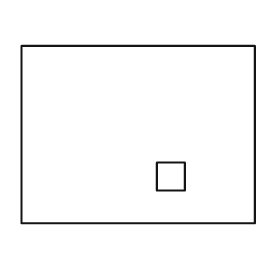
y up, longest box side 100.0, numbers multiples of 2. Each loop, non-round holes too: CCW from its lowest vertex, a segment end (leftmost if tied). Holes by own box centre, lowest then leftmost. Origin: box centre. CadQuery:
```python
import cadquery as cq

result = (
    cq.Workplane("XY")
    .moveTo(-50.0, -38.0)
    .lineTo(50.0, -38.0)
    .lineTo(50.0, 38.0)
    .lineTo(-50.0, 38.0)
    .close()
    .moveTo(8.0, -24.0)
    .lineTo(20.0, -24.0)
    .lineTo(20.0, -12.0)
    .lineTo(8.0, -12.0)
    .close()
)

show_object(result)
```